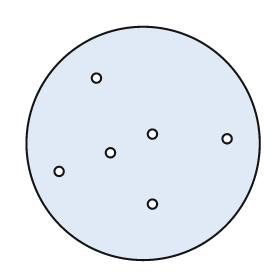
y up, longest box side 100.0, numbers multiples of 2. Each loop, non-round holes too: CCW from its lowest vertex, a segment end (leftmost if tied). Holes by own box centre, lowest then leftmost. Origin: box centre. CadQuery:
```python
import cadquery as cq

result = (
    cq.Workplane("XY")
    .moveTo(0.0, 0.0)
    .circle(50.0)
    .moveTo(4.0, -26.0)
    .circle(2.0)
    .moveTo(-36.0, -12.0)
    .circle(2.0)
    .moveTo(-14.0, -4.0)
    .circle(2.0)
    .moveTo(36.0, 2.0)
    .circle(2.0)
    .moveTo(4.0, 4.0)
    .circle(2.0)
    .moveTo(-20.0, 28.0)
    .circle(2.0)
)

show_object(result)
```